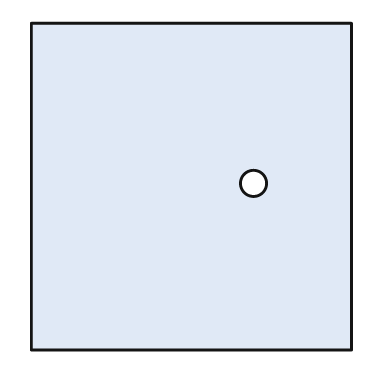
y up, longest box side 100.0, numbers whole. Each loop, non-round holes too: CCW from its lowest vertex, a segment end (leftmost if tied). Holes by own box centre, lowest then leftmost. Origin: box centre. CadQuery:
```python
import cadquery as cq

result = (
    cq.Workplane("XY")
    .moveTo(-49.0, -50.0)
    .lineTo(49.0, -50.0)
    .lineTo(49.0, 50.0)
    .lineTo(-49.0, 50.0)
    .close()
    .moveTo(19.0, 1.0)
    .circle(4.0)
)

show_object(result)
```